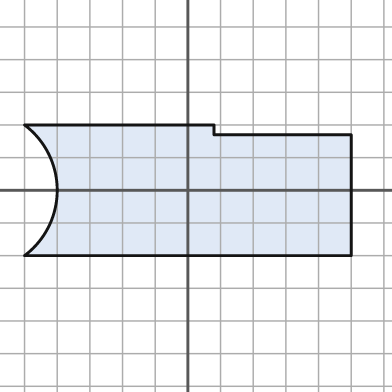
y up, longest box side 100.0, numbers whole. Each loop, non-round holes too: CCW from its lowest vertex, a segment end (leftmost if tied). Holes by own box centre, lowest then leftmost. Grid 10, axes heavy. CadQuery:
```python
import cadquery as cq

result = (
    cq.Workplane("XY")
    .moveTo(-50.0, -20.0)
    .lineTo(50.0, -20.0)
    .lineTo(50.0, 17.0)
    .lineTo(8.0, 17.0)
    .lineTo(8.0, 20.0)
    .lineTo(-50.0, 20.0)
    .threePointArc((-40.0, 0.0), (-50.0, -20.0))
    .close()
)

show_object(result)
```